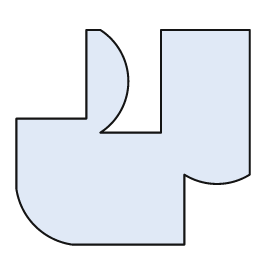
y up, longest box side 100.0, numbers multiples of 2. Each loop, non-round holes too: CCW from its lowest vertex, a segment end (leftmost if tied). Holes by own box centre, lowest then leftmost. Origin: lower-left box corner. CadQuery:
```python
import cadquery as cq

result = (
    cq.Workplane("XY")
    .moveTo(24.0, 0.0)
    .lineTo(72.0, 0.0)
    .lineTo(72.0, 30.0)
    .threePointArc((86.0, 26.0), (100.0, 30.0))
    .lineTo(100.0, 92.0)
    .lineTo(62.0, 92.0)
    .lineTo(62.0, 48.0)
    .lineTo(36.0, 48.0)
    .threePointArc((48.0, 70.0), (36.0, 92.0))
    .lineTo(30.0, 92.0)
    .lineTo(30.0, 54.0)
    .lineTo(0.0, 54.0)
    .lineTo(0.0, 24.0)
    .threePointArc((8.0, 8.0), (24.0, 0.0))
    .close()
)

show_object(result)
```